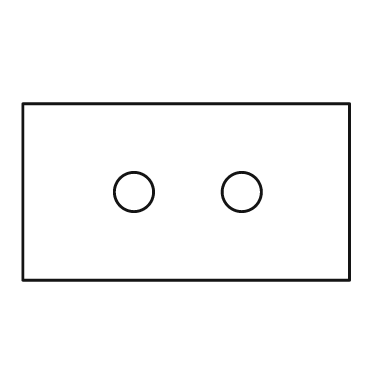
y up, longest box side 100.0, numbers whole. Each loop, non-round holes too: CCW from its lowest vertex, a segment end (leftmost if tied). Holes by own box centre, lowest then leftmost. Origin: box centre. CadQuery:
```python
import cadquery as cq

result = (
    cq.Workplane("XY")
    .moveTo(-50.0, -27.0)
    .lineTo(50.0, -27.0)
    .lineTo(50.0, 27.0)
    .lineTo(-50.0, 27.0)
    .close()
    .moveTo(-16.0, 0.0)
    .circle(6.0)
    .moveTo(17.0, 0.0)
    .circle(6.0)
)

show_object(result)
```